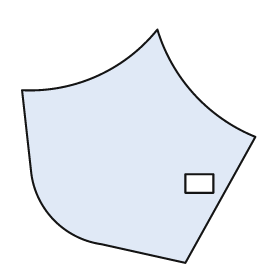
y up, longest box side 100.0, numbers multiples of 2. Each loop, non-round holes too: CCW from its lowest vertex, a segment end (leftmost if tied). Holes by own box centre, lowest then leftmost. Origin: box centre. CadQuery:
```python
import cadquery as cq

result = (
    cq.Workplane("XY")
    .moveTo(20.0, -50.0)
    .lineTo(50.0, 4.0)
    .threePointArc((24.0, 22.0), (8.0, 50.0))
    .threePointArc((-18.0, 30.0), (-50.0, 24.0))
    .lineTo(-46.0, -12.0)
    .threePointArc((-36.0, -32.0), (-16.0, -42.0))
    .close()
    .moveTo(20.0, -20.0)
    .lineTo(32.0, -20.0)
    .lineTo(32.0, -12.0)
    .lineTo(20.0, -12.0)
    .close()
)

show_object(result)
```